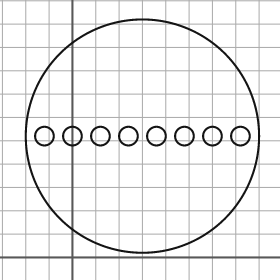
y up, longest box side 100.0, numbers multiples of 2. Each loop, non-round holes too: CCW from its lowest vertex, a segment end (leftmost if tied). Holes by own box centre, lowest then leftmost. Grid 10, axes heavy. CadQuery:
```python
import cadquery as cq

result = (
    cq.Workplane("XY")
    .moveTo(30.0, 52.0)
    .circle(50.0)
    .moveTo(-12.0, 52.0)
    .circle(4.0)
    .moveTo(0.0, 52.0)
    .circle(4.0)
    .moveTo(12.0, 52.0)
    .circle(4.0)
    .moveTo(24.0, 52.0)
    .circle(4.0)
    .moveTo(36.0, 52.0)
    .circle(4.0)
    .moveTo(48.0, 52.0)
    .circle(4.0)
    .moveTo(60.0, 52.0)
    .circle(4.0)
    .moveTo(72.0, 52.0)
    .circle(4.0)
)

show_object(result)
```